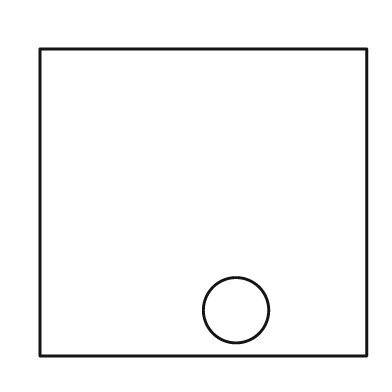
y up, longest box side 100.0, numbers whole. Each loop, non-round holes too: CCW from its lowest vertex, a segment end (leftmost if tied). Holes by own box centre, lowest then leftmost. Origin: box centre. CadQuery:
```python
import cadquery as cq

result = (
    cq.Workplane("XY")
    .moveTo(-50.0, -47.0)
    .lineTo(50.0, -47.0)
    .lineTo(50.0, 47.0)
    .lineTo(-50.0, 47.0)
    .close()
    .moveTo(10.0, -33.0)
    .circle(10.0)
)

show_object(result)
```